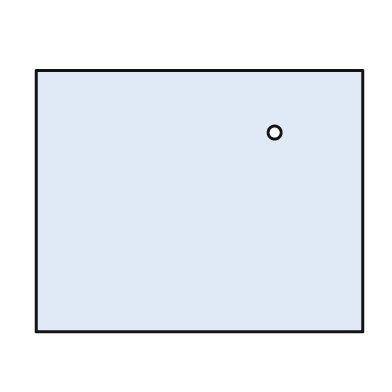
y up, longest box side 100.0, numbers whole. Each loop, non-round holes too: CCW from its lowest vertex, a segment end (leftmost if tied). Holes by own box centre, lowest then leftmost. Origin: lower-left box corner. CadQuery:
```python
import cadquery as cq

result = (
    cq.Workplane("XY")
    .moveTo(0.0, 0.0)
    .lineTo(100.0, 0.0)
    .lineTo(100.0, 80.0)
    .lineTo(0.0, 80.0)
    .close()
    .moveTo(73.0, 61.0)
    .circle(2.0)
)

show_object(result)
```